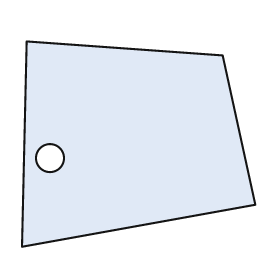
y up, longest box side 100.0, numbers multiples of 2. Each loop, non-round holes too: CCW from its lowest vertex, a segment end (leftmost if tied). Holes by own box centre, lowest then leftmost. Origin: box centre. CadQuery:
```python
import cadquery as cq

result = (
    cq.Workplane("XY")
    .moveTo(-50.0, -44.0)
    .lineTo(50.0, -26.0)
    .lineTo(36.0, 38.0)
    .lineTo(-48.0, 44.0)
    .close()
    .moveTo(-38.0, -6.0)
    .circle(6.0)
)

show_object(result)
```